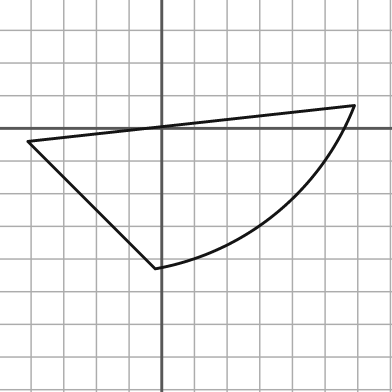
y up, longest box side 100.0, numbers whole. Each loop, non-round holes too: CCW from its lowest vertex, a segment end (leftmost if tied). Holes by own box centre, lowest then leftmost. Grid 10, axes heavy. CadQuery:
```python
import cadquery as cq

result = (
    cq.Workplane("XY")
    .moveTo(-2.0, -43.0)
    .threePointArc((35.0, -26.0), (59.0, 7.0))
    .lineTo(-41.0, -4.0)
    .close()
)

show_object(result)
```